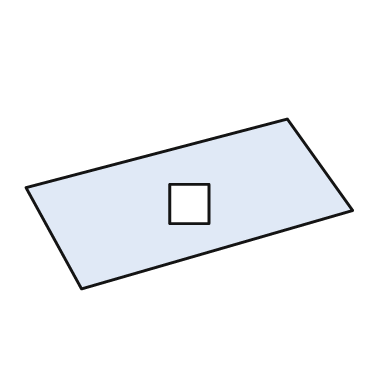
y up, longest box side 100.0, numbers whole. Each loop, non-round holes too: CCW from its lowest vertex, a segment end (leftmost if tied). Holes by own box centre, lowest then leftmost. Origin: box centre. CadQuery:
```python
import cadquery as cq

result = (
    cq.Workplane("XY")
    .moveTo(-33.0, -26.0)
    .lineTo(50.0, -2.0)
    .lineTo(30.0, 26.0)
    .lineTo(-50.0, 5.0)
    .close()
    .moveTo(-6.0, -6.0)
    .lineTo(6.0, -6.0)
    .lineTo(6.0, 6.0)
    .lineTo(-6.0, 6.0)
    .close()
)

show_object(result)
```